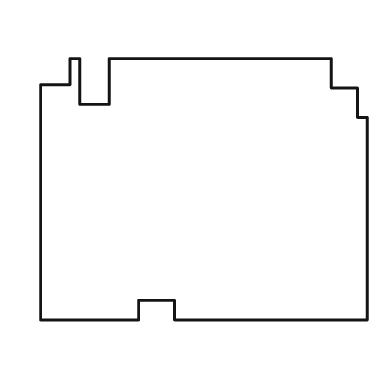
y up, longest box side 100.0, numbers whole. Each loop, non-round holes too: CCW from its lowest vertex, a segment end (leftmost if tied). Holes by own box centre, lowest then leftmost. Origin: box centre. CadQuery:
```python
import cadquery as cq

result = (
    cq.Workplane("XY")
    .moveTo(-50.0, -40.0)
    .lineTo(-20.0, -40.0)
    .lineTo(-20.0, -34.0)
    .lineTo(-9.0, -34.0)
    .lineTo(-9.0, -40.0)
    .lineTo(50.0, -40.0)
    .lineTo(50.0, 22.0)
    .lineTo(47.0, 22.0)
    .lineTo(47.0, 31.0)
    .lineTo(39.0, 31.0)
    .lineTo(39.0, 40.0)
    .lineTo(-29.0, 40.0)
    .lineTo(-29.0, 26.0)
    .lineTo(-38.0, 26.0)
    .lineTo(-38.0, 40.0)
    .lineTo(-41.0, 40.0)
    .lineTo(-41.0, 32.0)
    .lineTo(-50.0, 32.0)
    .close()
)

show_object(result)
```